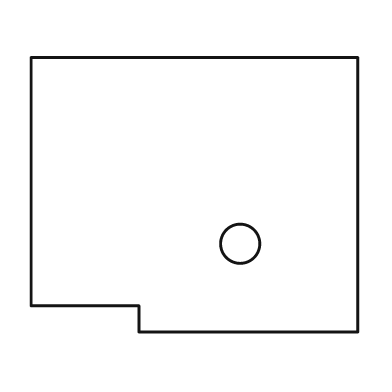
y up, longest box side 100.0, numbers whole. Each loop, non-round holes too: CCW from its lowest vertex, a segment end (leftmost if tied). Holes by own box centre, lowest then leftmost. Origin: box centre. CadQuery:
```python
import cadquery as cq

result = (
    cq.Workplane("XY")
    .moveTo(-17.0, -42.0)
    .lineTo(50.0, -42.0)
    .lineTo(50.0, 42.0)
    .lineTo(-50.0, 42.0)
    .lineTo(-50.0, -34.0)
    .lineTo(-17.0, -34.0)
    .close()
    .moveTo(14.0, -15.0)
    .circle(6.0)
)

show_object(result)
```